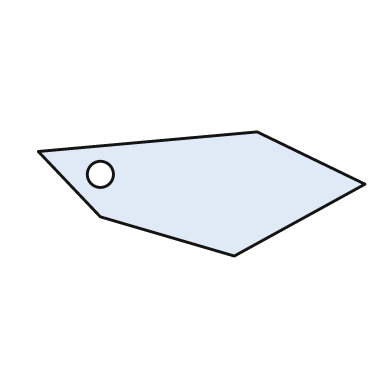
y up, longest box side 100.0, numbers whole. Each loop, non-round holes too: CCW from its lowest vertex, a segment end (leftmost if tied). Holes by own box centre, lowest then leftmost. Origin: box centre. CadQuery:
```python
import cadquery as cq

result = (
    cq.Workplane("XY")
    .moveTo(10.0, -19.0)
    .lineTo(50.0, 3.0)
    .lineTo(17.0, 19.0)
    .lineTo(-50.0, 13.0)
    .lineTo(-31.0, -7.0)
    .close()
    .moveTo(-31.0, 6.0)
    .circle(4.0)
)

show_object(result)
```